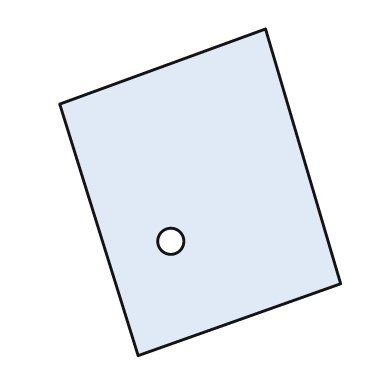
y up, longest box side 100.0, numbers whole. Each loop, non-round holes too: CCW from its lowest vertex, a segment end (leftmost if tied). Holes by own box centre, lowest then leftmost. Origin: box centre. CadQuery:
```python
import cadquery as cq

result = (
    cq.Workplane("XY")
    .moveTo(-19.0, -50.0)
    .lineTo(43.0, -28.0)
    .lineTo(20.0, 50.0)
    .lineTo(-43.0, 27.0)
    .close()
    .moveTo(-9.0, -15.0)
    .circle(4.0)
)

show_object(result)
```